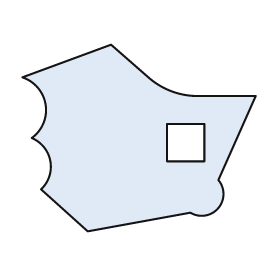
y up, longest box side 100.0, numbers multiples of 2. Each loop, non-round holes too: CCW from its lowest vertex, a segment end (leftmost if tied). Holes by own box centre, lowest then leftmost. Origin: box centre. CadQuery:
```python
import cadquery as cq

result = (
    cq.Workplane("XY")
    .moveTo(-22.0, -40.0)
    .lineTo(22.0, -32.0)
    .threePointArc((34.0, -30.0), (34.0, -18.0))
    .lineTo(50.0, 18.0)
    .lineTo(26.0, 18.0)
    .threePointArc((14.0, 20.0), (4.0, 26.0))
    .lineTo(-12.0, 40.0)
    .lineTo(-50.0, 26.0)
    .threePointArc((-40.0, 14.0), (-46.0, 0.0))
    .threePointArc((-38.0, -10.0), (-42.0, -22.0))
    .close()
    .moveTo(12.0, -10.0)
    .lineTo(28.0, -10.0)
    .lineTo(28.0, 6.0)
    .lineTo(12.0, 6.0)
    .close()
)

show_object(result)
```